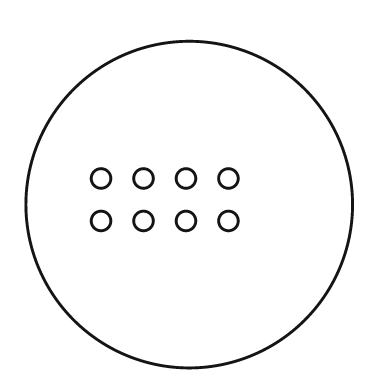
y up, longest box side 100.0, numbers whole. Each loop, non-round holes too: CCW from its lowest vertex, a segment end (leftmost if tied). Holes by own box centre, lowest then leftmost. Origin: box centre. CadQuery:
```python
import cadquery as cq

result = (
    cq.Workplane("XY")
    .moveTo(0.0, 0.0)
    .circle(50.0)
    .moveTo(-27.0, -5.0)
    .circle(3.0)
    .moveTo(-14.0, -5.0)
    .circle(3.0)
    .moveTo(-1.0, -5.0)
    .circle(3.0)
    .moveTo(12.0, -5.0)
    .circle(3.0)
    .moveTo(-27.0, 8.0)
    .circle(3.0)
    .moveTo(-14.0, 8.0)
    .circle(3.0)
    .moveTo(-1.0, 8.0)
    .circle(3.0)
    .moveTo(12.0, 8.0)
    .circle(3.0)
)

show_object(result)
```